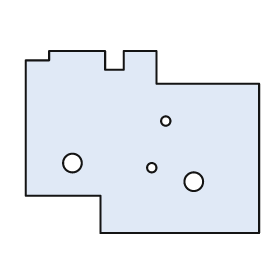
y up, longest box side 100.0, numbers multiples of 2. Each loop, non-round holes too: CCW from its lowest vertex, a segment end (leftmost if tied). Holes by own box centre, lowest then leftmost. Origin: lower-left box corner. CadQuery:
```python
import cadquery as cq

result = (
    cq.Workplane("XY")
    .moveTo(32.0, 0.0)
    .lineTo(100.0, 0.0)
    .lineTo(100.0, 64.0)
    .lineTo(56.0, 64.0)
    .lineTo(56.0, 78.0)
    .lineTo(42.0, 78.0)
    .lineTo(42.0, 70.0)
    .lineTo(34.0, 70.0)
    .lineTo(34.0, 78.0)
    .lineTo(10.0, 78.0)
    .lineTo(10.0, 74.0)
    .lineTo(0.0, 74.0)
    .lineTo(0.0, 16.0)
    .lineTo(32.0, 16.0)
    .close()
    .moveTo(72.0, 22.0)
    .circle(4.0)
    .moveTo(54.0, 28.0)
    .circle(2.0)
    .moveTo(20.0, 30.0)
    .circle(4.0)
    .moveTo(60.0, 48.0)
    .circle(2.0)
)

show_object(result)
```